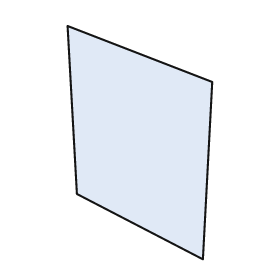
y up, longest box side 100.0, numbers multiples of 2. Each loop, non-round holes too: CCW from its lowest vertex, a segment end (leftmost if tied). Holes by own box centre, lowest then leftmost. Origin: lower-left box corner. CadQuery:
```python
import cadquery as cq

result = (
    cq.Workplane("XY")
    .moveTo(58.0, 0.0)
    .lineTo(62.0, 76.0)
    .lineTo(0.0, 100.0)
    .lineTo(4.0, 28.0)
    .close()
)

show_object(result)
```